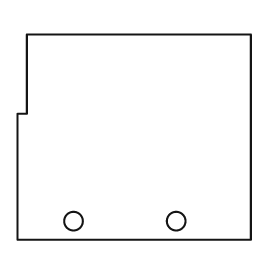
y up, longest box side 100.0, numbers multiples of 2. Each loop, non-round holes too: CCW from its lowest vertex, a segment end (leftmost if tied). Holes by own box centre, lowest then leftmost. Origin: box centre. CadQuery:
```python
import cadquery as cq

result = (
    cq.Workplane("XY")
    .moveTo(-50.0, -44.0)
    .lineTo(50.0, -44.0)
    .lineTo(50.0, 44.0)
    .lineTo(-46.0, 44.0)
    .lineTo(-46.0, 10.0)
    .lineTo(-50.0, 10.0)
    .close()
    .moveTo(-26.0, -36.0)
    .circle(4.0)
    .moveTo(18.0, -36.0)
    .circle(4.0)
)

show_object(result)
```